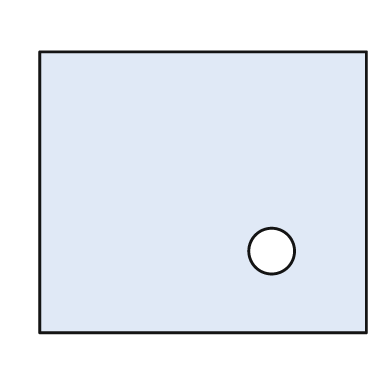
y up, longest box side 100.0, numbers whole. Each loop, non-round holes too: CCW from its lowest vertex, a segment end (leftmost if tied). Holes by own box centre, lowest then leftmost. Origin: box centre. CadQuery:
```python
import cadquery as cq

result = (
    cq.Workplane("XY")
    .moveTo(-50.0, -43.0)
    .lineTo(50.0, -43.0)
    .lineTo(50.0, 43.0)
    .lineTo(-50.0, 43.0)
    .close()
    .moveTo(21.0, -18.0)
    .circle(7.0)
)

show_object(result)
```